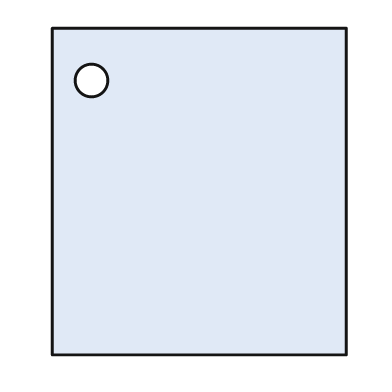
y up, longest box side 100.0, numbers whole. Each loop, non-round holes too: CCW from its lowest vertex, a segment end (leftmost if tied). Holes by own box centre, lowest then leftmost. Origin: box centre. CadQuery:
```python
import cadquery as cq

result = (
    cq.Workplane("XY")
    .moveTo(-45.0, -50.0)
    .lineTo(45.0, -50.0)
    .lineTo(45.0, 50.0)
    .lineTo(-45.0, 50.0)
    .close()
    .moveTo(-33.0, 34.0)
    .circle(5.0)
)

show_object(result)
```